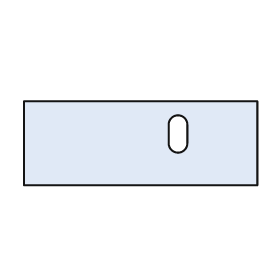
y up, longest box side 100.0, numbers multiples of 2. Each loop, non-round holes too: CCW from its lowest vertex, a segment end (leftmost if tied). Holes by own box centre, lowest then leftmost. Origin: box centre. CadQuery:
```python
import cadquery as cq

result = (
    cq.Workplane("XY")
    .moveTo(-50.0, -18.0)
    .lineTo(50.0, -18.0)
    .lineTo(50.0, 18.0)
    .lineTo(-50.0, 18.0)
    .close()
    .moveTo(12.0, 0.0)
    .threePointArc((16.0, -4.0), (20.0, 0.0))
    .lineTo(20.0, 8.0)
    .threePointArc((16.0, 12.0), (12.0, 8.0))
    .close()
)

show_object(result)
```